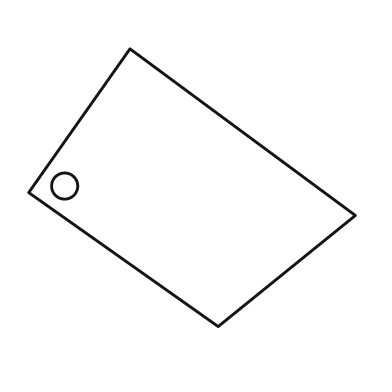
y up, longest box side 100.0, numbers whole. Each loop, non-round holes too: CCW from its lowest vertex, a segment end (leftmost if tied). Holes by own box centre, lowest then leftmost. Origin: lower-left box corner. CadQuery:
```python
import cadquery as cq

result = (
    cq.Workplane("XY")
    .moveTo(58.0, 0.0)
    .lineTo(100.0, 34.0)
    .lineTo(31.0, 85.0)
    .lineTo(0.0, 41.0)
    .close()
    .moveTo(11.0, 43.0)
    .circle(4.0)
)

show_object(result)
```